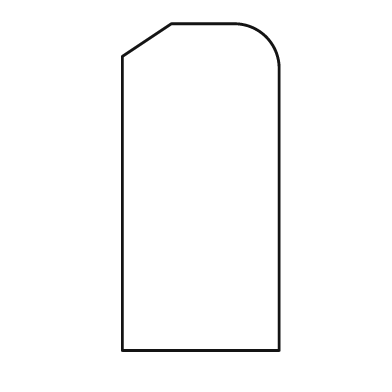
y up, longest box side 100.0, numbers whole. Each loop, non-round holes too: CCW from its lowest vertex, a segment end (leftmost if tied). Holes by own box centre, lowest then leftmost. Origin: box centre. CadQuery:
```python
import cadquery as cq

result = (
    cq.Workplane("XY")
    .moveTo(-24.0, -50.0)
    .lineTo(24.0, -50.0)
    .lineTo(24.0, 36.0)
    .threePointArc((20.0, 46.0), (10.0, 50.0))
    .lineTo(-9.0, 50.0)
    .lineTo(-24.0, 40.0)
    .close()
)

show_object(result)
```